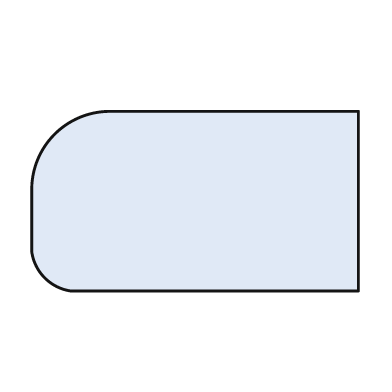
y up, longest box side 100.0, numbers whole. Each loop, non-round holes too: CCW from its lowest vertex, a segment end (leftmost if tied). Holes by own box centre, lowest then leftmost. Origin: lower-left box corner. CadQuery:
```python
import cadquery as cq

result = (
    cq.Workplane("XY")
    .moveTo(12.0, 0.0)
    .lineTo(100.0, 0.0)
    .lineTo(100.0, 55.0)
    .lineTo(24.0, 55.0)
    .threePointArc((7.0, 48.0), (0.0, 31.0))
    .lineTo(0.0, 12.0)
    .threePointArc((4.0, 4.0), (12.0, 0.0))
    .close()
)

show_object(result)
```